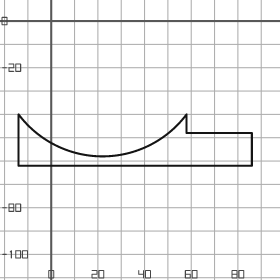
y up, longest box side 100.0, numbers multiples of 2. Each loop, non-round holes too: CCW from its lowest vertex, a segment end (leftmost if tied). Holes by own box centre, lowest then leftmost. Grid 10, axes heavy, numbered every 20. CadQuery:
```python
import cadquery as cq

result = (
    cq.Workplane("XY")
    .moveTo(-14.0, -62.0)
    .lineTo(86.0, -62.0)
    .lineTo(86.0, -48.0)
    .lineTo(58.0, -48.0)
    .lineTo(58.0, -40.0)
    .threePointArc((22.0, -58.0), (-14.0, -40.0))
    .close()
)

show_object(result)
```